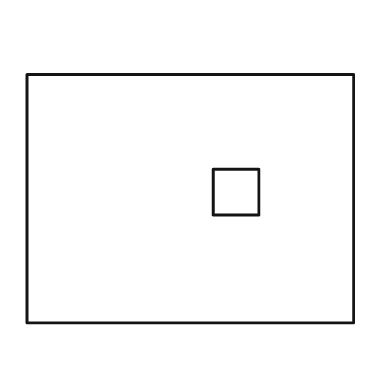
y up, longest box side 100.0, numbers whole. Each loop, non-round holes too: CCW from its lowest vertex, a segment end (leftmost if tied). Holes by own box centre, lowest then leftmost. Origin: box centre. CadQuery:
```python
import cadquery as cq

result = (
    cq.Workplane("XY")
    .moveTo(-50.0, -38.0)
    .lineTo(50.0, -38.0)
    .lineTo(50.0, 38.0)
    .lineTo(-50.0, 38.0)
    .close()
    .moveTo(7.0, -5.0)
    .lineTo(21.0, -5.0)
    .lineTo(21.0, 9.0)
    .lineTo(7.0, 9.0)
    .close()
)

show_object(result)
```